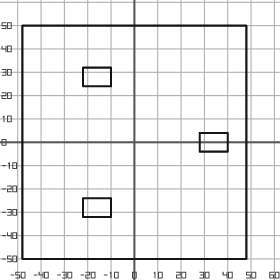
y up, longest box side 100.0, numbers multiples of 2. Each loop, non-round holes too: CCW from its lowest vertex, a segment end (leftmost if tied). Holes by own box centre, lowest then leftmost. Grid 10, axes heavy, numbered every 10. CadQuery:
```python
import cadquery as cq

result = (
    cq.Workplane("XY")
    .moveTo(-48.0, -50.0)
    .lineTo(48.0, -50.0)
    .lineTo(48.0, 50.0)
    .lineTo(-48.0, 50.0)
    .close()
    .moveTo(-22.0, -32.0)
    .lineTo(-10.0, -32.0)
    .lineTo(-10.0, -24.0)
    .lineTo(-22.0, -24.0)
    .close()
    .moveTo(28.0, -4.0)
    .lineTo(40.0, -4.0)
    .lineTo(40.0, 4.0)
    .lineTo(28.0, 4.0)
    .close()
    .moveTo(-22.0, 24.0)
    .lineTo(-10.0, 24.0)
    .lineTo(-10.0, 32.0)
    .lineTo(-22.0, 32.0)
    .close()
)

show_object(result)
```